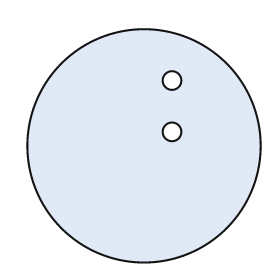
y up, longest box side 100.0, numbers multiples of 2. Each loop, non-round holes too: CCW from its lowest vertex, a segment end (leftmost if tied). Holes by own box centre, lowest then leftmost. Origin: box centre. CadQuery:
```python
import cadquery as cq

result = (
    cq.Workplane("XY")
    .moveTo(0.0, 0.0)
    .circle(50.0)
    .moveTo(12.0, 6.0)
    .circle(4.0)
    .moveTo(12.0, 28.0)
    .circle(4.0)
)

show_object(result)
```